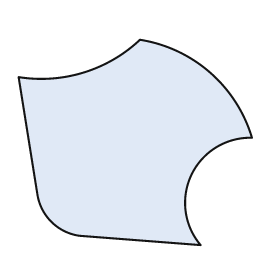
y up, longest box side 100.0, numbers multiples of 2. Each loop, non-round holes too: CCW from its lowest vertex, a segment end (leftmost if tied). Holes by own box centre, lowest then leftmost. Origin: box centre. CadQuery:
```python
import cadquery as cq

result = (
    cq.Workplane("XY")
    .moveTo(28.0, -44.0)
    .threePointArc((24.0, -14.0), (50.0, 2.0))
    .threePointArc((32.0, 30.0), (2.0, 44.0))
    .threePointArc((-22.0, 30.0), (-50.0, 28.0))
    .lineTo(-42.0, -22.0)
    .threePointArc((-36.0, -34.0), (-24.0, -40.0))
    .close()
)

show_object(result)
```